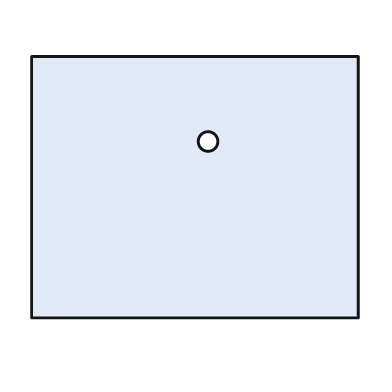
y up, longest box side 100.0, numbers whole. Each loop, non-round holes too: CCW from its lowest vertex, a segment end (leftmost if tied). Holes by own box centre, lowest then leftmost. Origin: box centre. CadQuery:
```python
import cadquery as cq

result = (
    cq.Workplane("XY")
    .moveTo(-50.0, -40.0)
    .lineTo(50.0, -40.0)
    .lineTo(50.0, 40.0)
    .lineTo(-50.0, 40.0)
    .close()
    .moveTo(4.0, 14.0)
    .circle(3.0)
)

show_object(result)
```